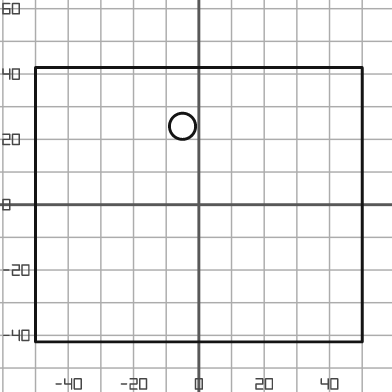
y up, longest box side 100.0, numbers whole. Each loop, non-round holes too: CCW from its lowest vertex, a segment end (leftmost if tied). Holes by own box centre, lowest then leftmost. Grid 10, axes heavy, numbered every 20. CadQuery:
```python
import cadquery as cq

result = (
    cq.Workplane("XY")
    .moveTo(-50.0, -42.0)
    .lineTo(50.0, -42.0)
    .lineTo(50.0, 42.0)
    .lineTo(-50.0, 42.0)
    .close()
    .moveTo(-5.0, 24.0)
    .circle(4.0)
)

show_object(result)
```